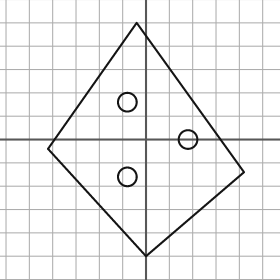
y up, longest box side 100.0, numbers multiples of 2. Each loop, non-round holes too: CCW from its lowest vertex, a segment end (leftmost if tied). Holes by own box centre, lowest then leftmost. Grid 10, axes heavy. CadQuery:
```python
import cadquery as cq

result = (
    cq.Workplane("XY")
    .moveTo(0.0, -50.0)
    .lineTo(42.0, -14.0)
    .lineTo(-4.0, 50.0)
    .lineTo(-42.0, -4.0)
    .close()
    .moveTo(-8.0, -16.0)
    .circle(4.0)
    .moveTo(18.0, 0.0)
    .circle(4.0)
    .moveTo(-8.0, 16.0)
    .circle(4.0)
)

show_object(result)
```